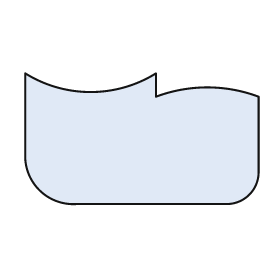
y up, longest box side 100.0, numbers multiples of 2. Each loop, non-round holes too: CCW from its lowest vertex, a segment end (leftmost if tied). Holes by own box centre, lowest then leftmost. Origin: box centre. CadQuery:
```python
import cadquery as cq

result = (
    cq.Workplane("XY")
    .moveTo(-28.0, -28.0)
    .lineTo(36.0, -28.0)
    .threePointArc((46.0, -24.0), (50.0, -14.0))
    .lineTo(50.0, 18.0)
    .threePointArc((28.0, 22.0), (6.0, 18.0))
    .lineTo(6.0, 28.0)
    .threePointArc((-22.0, 20.0), (-50.0, 28.0))
    .lineTo(-50.0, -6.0)
    .threePointArc((-44.0, -22.0), (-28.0, -28.0))
    .close()
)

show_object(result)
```